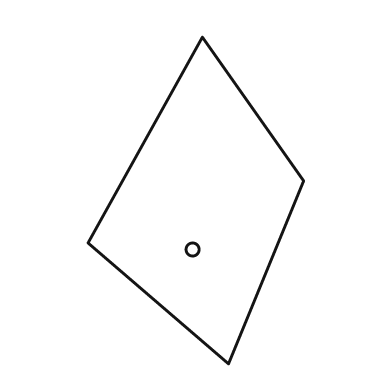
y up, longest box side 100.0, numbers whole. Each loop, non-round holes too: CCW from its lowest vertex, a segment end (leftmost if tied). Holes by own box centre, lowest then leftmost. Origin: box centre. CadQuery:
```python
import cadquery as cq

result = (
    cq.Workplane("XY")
    .moveTo(10.0, -50.0)
    .lineTo(33.0, 6.0)
    .lineTo(2.0, 50.0)
    .lineTo(-33.0, -13.0)
    .close()
    .moveTo(-1.0, -15.0)
    .circle(2.0)
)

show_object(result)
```